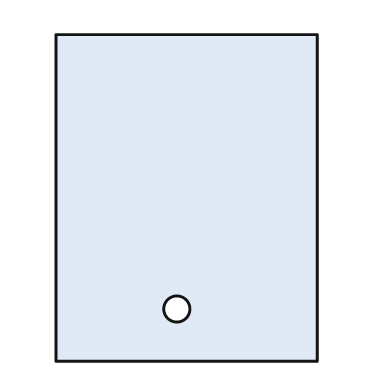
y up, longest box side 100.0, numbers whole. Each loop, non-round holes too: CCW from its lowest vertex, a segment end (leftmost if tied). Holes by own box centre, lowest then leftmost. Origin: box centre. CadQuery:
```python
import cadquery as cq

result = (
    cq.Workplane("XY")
    .moveTo(-40.0, -50.0)
    .lineTo(40.0, -50.0)
    .lineTo(40.0, 50.0)
    .lineTo(-40.0, 50.0)
    .close()
    .moveTo(-3.0, -34.0)
    .circle(4.0)
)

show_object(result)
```